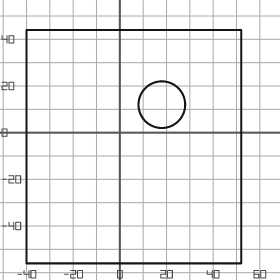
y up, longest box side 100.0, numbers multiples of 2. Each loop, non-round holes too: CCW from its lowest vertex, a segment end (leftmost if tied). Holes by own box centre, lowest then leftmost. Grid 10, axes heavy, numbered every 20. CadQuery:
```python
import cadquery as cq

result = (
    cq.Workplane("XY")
    .moveTo(-40.0, -56.0)
    .lineTo(52.0, -56.0)
    .lineTo(52.0, 44.0)
    .lineTo(-40.0, 44.0)
    .close()
    .moveTo(18.0, 12.0)
    .circle(10.0)
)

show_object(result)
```